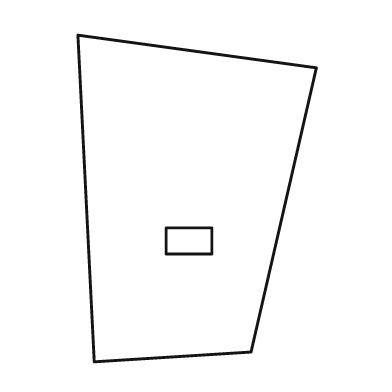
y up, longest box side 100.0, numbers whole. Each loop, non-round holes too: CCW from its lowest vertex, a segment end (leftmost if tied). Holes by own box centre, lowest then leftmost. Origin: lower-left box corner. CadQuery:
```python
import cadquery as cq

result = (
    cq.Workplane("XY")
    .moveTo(5.0, 0.0)
    .lineTo(53.0, 3.0)
    .lineTo(73.0, 90.0)
    .lineTo(0.0, 100.0)
    .close()
    .moveTo(27.0, 33.0)
    .lineTo(41.0, 33.0)
    .lineTo(41.0, 41.0)
    .lineTo(27.0, 41.0)
    .close()
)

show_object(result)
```